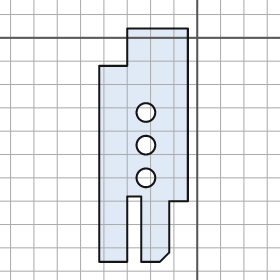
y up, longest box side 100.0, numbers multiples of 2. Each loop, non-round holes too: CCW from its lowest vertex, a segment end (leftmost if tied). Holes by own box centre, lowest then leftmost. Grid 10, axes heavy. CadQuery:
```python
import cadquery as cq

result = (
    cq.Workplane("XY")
    .moveTo(-42.0, -96.0)
    .lineTo(-30.0, -96.0)
    .lineTo(-30.0, -68.0)
    .lineTo(-24.0, -68.0)
    .lineTo(-24.0, -96.0)
    .lineTo(-16.0, -96.0)
    .lineTo(-12.0, -92.0)
    .lineTo(-12.0, -70.0)
    .lineTo(-4.0, -70.0)
    .lineTo(-4.0, 4.0)
    .lineTo(-30.0, 4.0)
    .lineTo(-30.0, -12.0)
    .lineTo(-42.0, -12.0)
    .close()
    .moveTo(-22.0, -60.0)
    .circle(4.0)
    .moveTo(-22.0, -46.0)
    .circle(4.0)
    .moveTo(-22.0, -32.0)
    .circle(4.0)
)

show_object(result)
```